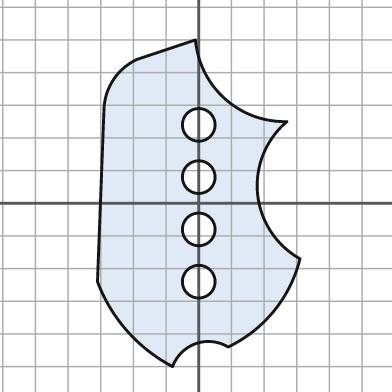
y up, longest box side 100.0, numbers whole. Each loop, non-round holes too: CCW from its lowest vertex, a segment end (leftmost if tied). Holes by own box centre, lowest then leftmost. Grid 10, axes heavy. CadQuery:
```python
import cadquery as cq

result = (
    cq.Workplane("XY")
    .moveTo(-8.0, -50.0)
    .threePointArc((-1.0, -43.0), (9.0, -44.0))
    .threePointArc((23.0, -33.0), (31.0, -17.0))
    .threePointArc((18.0, 3.0), (27.0, 25.0))
    .threePointArc((8.0, 32.0), (-1.0, 50.0))
    .lineTo(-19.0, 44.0)
    .threePointArc((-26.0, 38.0), (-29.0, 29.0))
    .lineTo(-31.0, -24.0)
    .threePointArc((-22.0, -39.0), (-8.0, -50.0))
    .close()
    .moveTo(0.0, -24.0)
    .circle(5.0)
    .moveTo(0.0, -8.0)
    .circle(5.0)
    .moveTo(0.0, 8.0)
    .circle(5.0)
    .moveTo(0.0, 24.0)
    .circle(5.0)
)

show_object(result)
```